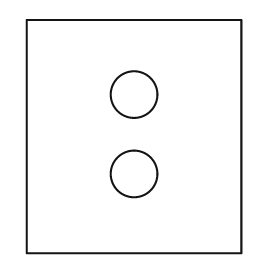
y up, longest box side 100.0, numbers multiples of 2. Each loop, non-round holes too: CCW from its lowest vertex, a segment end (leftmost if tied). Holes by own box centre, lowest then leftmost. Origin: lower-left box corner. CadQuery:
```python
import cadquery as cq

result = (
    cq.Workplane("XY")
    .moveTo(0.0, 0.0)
    .lineTo(92.0, 0.0)
    .lineTo(92.0, 100.0)
    .lineTo(0.0, 100.0)
    .close()
    .moveTo(46.0, 34.0)
    .circle(10.0)
    .moveTo(46.0, 68.0)
    .circle(10.0)
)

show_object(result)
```